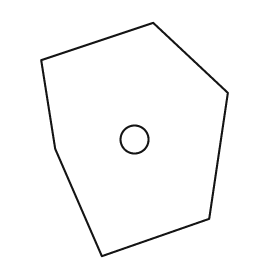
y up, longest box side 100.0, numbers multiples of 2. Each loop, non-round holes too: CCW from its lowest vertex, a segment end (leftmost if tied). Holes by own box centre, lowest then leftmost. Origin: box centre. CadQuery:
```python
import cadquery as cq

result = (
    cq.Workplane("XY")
    .moveTo(-14.0, -50.0)
    .lineTo(32.0, -34.0)
    .lineTo(40.0, 20.0)
    .lineTo(8.0, 50.0)
    .lineTo(-40.0, 34.0)
    .lineTo(-34.0, -4.0)
    .close()
    .moveTo(0.0, 0.0)
    .circle(6.0)
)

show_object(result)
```